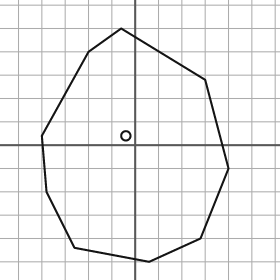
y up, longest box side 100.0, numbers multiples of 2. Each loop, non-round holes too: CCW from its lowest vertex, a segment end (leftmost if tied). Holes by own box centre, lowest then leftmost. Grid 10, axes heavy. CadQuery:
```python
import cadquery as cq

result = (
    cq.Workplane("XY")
    .moveTo(6.0, -50.0)
    .lineTo(28.0, -40.0)
    .lineTo(40.0, -10.0)
    .lineTo(30.0, 28.0)
    .lineTo(-6.0, 50.0)
    .lineTo(-20.0, 40.0)
    .lineTo(-40.0, 4.0)
    .lineTo(-38.0, -20.0)
    .lineTo(-26.0, -44.0)
    .close()
    .moveTo(-4.0, 4.0)
    .circle(2.0)
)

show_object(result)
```